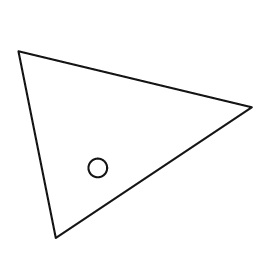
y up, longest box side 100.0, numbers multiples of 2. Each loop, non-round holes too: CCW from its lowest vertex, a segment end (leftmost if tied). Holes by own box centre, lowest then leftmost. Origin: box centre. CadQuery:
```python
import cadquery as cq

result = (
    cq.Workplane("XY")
    .moveTo(-34.0, -40.0)
    .lineTo(50.0, 16.0)
    .lineTo(-50.0, 40.0)
    .close()
    .moveTo(-16.0, -10.0)
    .circle(4.0)
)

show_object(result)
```